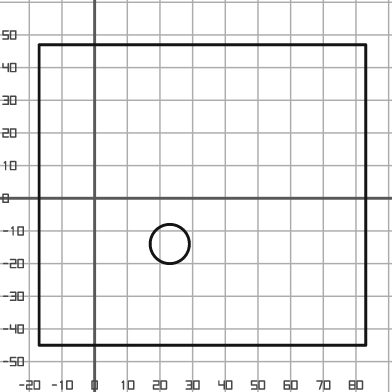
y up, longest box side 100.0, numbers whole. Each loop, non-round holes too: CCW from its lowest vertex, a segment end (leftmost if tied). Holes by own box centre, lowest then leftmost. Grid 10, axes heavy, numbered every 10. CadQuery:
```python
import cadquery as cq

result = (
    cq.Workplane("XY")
    .moveTo(-17.0, -45.0)
    .lineTo(83.0, -45.0)
    .lineTo(83.0, 47.0)
    .lineTo(-17.0, 47.0)
    .close()
    .moveTo(23.0, -14.0)
    .circle(6.0)
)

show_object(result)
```